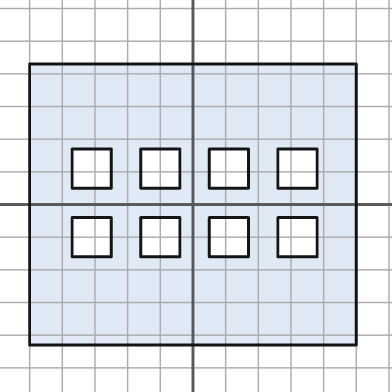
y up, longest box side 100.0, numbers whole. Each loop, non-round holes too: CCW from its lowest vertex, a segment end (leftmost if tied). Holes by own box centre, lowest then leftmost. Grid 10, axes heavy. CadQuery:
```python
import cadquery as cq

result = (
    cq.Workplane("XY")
    .moveTo(-50.0, -43.0)
    .lineTo(50.0, -43.0)
    .lineTo(50.0, 43.0)
    .lineTo(-50.0, 43.0)
    .close()
    .moveTo(-37.0, -16.0)
    .lineTo(-25.0, -16.0)
    .lineTo(-25.0, -4.0)
    .lineTo(-37.0, -4.0)
    .close()
    .moveTo(-16.0, -16.0)
    .lineTo(-4.0, -16.0)
    .lineTo(-4.0, -4.0)
    .lineTo(-16.0, -4.0)
    .close()
    .moveTo(5.0, -16.0)
    .lineTo(17.0, -16.0)
    .lineTo(17.0, -4.0)
    .lineTo(5.0, -4.0)
    .close()
    .moveTo(26.0, -16.0)
    .lineTo(38.0, -16.0)
    .lineTo(38.0, -4.0)
    .lineTo(26.0, -4.0)
    .close()
    .moveTo(-37.0, 5.0)
    .lineTo(-25.0, 5.0)
    .lineTo(-25.0, 17.0)
    .lineTo(-37.0, 17.0)
    .close()
    .moveTo(-16.0, 5.0)
    .lineTo(-4.0, 5.0)
    .lineTo(-4.0, 17.0)
    .lineTo(-16.0, 17.0)
    .close()
    .moveTo(5.0, 5.0)
    .lineTo(17.0, 5.0)
    .lineTo(17.0, 17.0)
    .lineTo(5.0, 17.0)
    .close()
    .moveTo(26.0, 5.0)
    .lineTo(38.0, 5.0)
    .lineTo(38.0, 17.0)
    .lineTo(26.0, 17.0)
    .close()
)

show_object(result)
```